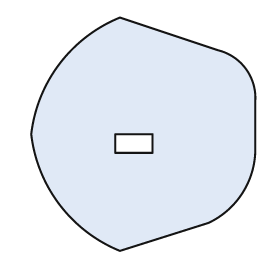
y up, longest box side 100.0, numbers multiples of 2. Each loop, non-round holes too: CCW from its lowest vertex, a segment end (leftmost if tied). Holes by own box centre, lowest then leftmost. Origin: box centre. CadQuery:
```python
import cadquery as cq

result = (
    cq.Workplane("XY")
    .moveTo(-10.0, -50.0)
    .lineTo(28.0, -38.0)
    .threePointArc((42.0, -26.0), (48.0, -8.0))
    .lineTo(48.0, 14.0)
    .threePointArc((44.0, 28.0), (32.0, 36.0))
    .lineTo(-10.0, 50.0)
    .threePointArc((-36.0, 30.0), (-48.0, 0.0))
    .threePointArc((-36.0, -30.0), (-10.0, -50.0))
    .close()
    .moveTo(-12.0, -8.0)
    .lineTo(4.0, -8.0)
    .lineTo(4.0, 0.0)
    .lineTo(-12.0, 0.0)
    .close()
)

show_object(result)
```